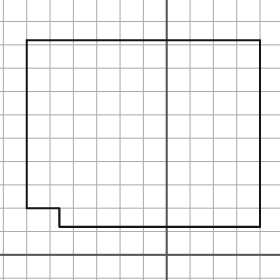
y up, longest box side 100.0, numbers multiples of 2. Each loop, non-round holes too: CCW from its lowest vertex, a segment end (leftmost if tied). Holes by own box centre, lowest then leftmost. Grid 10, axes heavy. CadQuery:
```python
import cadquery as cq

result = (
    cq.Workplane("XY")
    .moveTo(-46.0, 12.0)
    .lineTo(40.0, 12.0)
    .lineTo(40.0, 92.0)
    .lineTo(-60.0, 92.0)
    .lineTo(-60.0, 20.0)
    .lineTo(-46.0, 20.0)
    .close()
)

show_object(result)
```